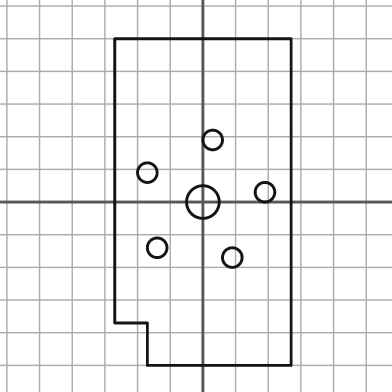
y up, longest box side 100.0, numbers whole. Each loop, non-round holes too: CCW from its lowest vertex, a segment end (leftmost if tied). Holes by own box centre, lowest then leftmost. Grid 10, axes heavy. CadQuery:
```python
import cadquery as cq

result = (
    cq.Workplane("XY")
    .moveTo(-17.0, -50.0)
    .lineTo(27.0, -50.0)
    .lineTo(27.0, 50.0)
    .lineTo(-27.0, 50.0)
    .lineTo(-27.0, -37.0)
    .lineTo(-17.0, -37.0)
    .close()
    .moveTo(9.0, -17.0)
    .circle(3.0)
    .moveTo(-14.0, -14.0)
    .circle(3.0)
    .moveTo(0.0, 0.0)
    .circle(5.0)
    .moveTo(19.0, 3.0)
    .circle(3.0)
    .moveTo(-17.0, 9.0)
    .circle(3.0)
    .moveTo(3.0, 19.0)
    .circle(3.0)
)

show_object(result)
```